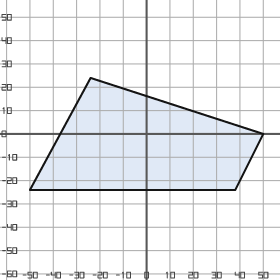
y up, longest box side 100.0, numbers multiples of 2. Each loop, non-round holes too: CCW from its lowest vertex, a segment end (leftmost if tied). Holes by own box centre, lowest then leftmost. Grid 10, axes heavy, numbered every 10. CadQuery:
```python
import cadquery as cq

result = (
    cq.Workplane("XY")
    .moveTo(-50.0, -24.0)
    .lineTo(38.0, -24.0)
    .lineTo(50.0, 0.0)
    .lineTo(-24.0, 24.0)
    .close()
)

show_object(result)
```